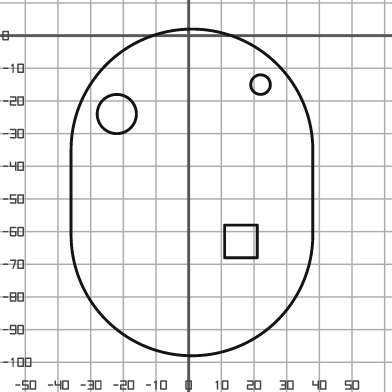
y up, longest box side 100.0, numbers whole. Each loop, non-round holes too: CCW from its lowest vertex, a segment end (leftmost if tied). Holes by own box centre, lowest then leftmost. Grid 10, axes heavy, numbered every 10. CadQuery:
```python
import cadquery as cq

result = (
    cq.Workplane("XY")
    .moveTo(-36.0, -61.0)
    .threePointArc((1.0, -98.0), (38.0, -61.0))
    .lineTo(38.0, -35.0)
    .threePointArc((1.0, 2.0), (-36.0, -35.0))
    .close()
    .moveTo(11.0, -68.0)
    .lineTo(21.0, -68.0)
    .lineTo(21.0, -58.0)
    .lineTo(11.0, -58.0)
    .close()
    .moveTo(-22.0, -24.0)
    .circle(6.0)
    .moveTo(22.0, -15.0)
    .circle(3.0)
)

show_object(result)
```